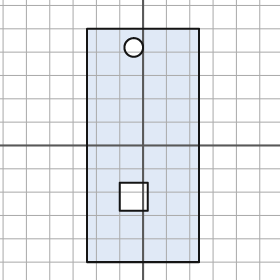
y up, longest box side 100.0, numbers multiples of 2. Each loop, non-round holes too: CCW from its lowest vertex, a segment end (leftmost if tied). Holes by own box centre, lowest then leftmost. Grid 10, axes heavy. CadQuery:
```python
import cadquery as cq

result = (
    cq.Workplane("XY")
    .moveTo(-24.0, -50.0)
    .lineTo(24.0, -50.0)
    .lineTo(24.0, 50.0)
    .lineTo(-24.0, 50.0)
    .close()
    .moveTo(-10.0, -28.0)
    .lineTo(2.0, -28.0)
    .lineTo(2.0, -16.0)
    .lineTo(-10.0, -16.0)
    .close()
    .moveTo(-4.0, 42.0)
    .circle(4.0)
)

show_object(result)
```